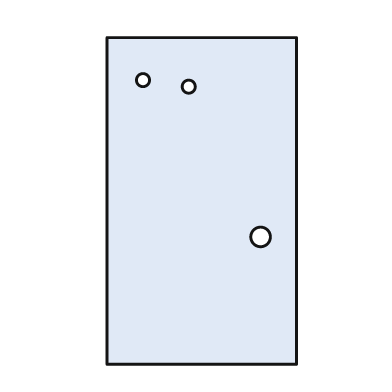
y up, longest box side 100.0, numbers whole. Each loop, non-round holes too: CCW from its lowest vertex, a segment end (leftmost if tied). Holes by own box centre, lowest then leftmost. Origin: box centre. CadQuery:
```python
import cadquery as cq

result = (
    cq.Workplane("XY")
    .moveTo(-29.0, -50.0)
    .lineTo(29.0, -50.0)
    .lineTo(29.0, 50.0)
    .lineTo(-29.0, 50.0)
    .close()
    .moveTo(18.0, -11.0)
    .circle(3.0)
    .moveTo(-4.0, 35.0)
    .circle(2.0)
    .moveTo(-18.0, 37.0)
    .circle(2.0)
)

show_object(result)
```